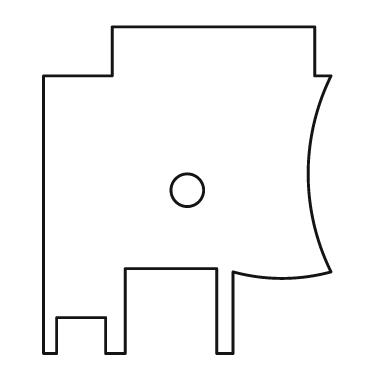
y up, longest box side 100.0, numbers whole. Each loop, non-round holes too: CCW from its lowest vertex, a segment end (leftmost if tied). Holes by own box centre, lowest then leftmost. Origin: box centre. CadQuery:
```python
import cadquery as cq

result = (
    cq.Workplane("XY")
    .moveTo(-44.0, -50.0)
    .lineTo(-40.0, -50.0)
    .lineTo(-40.0, -39.0)
    .lineTo(-25.0, -39.0)
    .lineTo(-25.0, -50.0)
    .lineTo(-19.0, -50.0)
    .lineTo(-19.0, -24.0)
    .lineTo(9.0, -24.0)
    .lineTo(9.0, -50.0)
    .lineTo(14.0, -50.0)
    .lineTo(14.0, -25.0)
    .threePointArc((29.0, -27.0), (44.0, -25.0))
    .threePointArc((37.0, 5.0), (44.0, 35.0))
    .lineTo(39.0, 35.0)
    .lineTo(39.0, 50.0)
    .lineTo(-23.0, 50.0)
    .lineTo(-23.0, 35.0)
    .lineTo(-44.0, 35.0)
    .close()
    .moveTo(0.0, 0.0)
    .circle(5.0)
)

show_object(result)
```